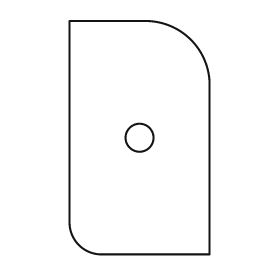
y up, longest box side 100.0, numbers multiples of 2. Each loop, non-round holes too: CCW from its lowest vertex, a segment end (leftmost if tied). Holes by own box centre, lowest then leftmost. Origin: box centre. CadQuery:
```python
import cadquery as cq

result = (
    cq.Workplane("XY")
    .moveTo(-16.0, -50.0)
    .lineTo(30.0, -50.0)
    .lineTo(30.0, 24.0)
    .threePointArc((22.0, 42.0), (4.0, 50.0))
    .lineTo(-30.0, 50.0)
    .lineTo(-30.0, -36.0)
    .threePointArc((-26.0, -46.0), (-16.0, -50.0))
    .close()
    .moveTo(0.0, 0.0)
    .circle(6.0)
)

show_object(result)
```